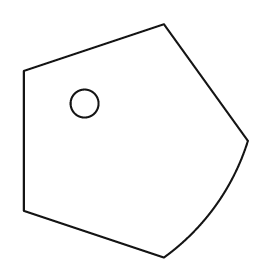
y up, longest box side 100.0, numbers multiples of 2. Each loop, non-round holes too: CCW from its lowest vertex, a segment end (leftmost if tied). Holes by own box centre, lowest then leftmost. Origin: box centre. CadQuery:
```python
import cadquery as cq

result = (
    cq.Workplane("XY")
    .moveTo(12.0, -50.0)
    .threePointArc((34.0, -28.0), (48.0, 0.0))
    .lineTo(12.0, 50.0)
    .lineTo(-48.0, 30.0)
    .lineTo(-48.0, -30.0)
    .close()
    .moveTo(-22.0, 16.0)
    .circle(6.0)
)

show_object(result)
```